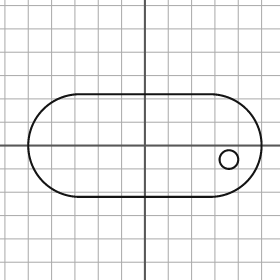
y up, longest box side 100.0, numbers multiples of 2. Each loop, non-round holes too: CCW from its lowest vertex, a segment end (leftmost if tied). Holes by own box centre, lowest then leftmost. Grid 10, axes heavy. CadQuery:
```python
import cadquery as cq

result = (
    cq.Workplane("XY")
    .moveTo(-28.0, -22.0)
    .lineTo(28.0, -22.0)
    .threePointArc((50.0, 0.0), (28.0, 22.0))
    .lineTo(-28.0, 22.0)
    .threePointArc((-50.0, 0.0), (-28.0, -22.0))
    .close()
    .moveTo(36.0, -6.0)
    .circle(4.0)
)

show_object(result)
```